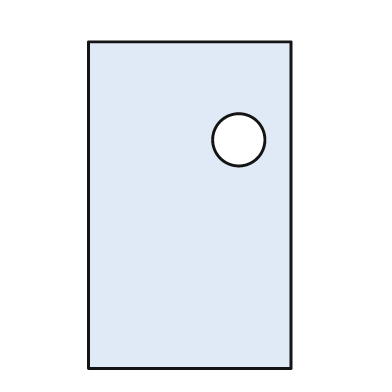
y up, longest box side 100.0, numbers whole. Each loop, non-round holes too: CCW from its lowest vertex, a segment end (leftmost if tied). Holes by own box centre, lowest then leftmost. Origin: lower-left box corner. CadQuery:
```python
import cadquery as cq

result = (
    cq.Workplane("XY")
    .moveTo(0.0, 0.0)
    .lineTo(62.0, 0.0)
    .lineTo(62.0, 100.0)
    .lineTo(0.0, 100.0)
    .close()
    .moveTo(46.0, 70.0)
    .circle(8.0)
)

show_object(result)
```